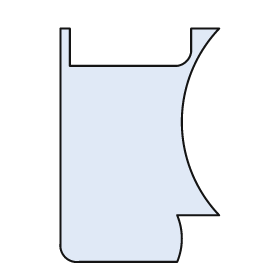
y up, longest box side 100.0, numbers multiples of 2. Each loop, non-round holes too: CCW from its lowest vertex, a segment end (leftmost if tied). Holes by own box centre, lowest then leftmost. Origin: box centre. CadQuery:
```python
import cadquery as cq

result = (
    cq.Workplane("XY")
    .moveTo(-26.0, -50.0)
    .lineTo(16.0, -50.0)
    .threePointArc((18.0, -40.0), (16.0, -30.0))
    .lineTo(34.0, -30.0)
    .threePointArc((18.0, 10.0), (34.0, 50.0))
    .lineTo(22.0, 50.0)
    .lineTo(22.0, 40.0)
    .threePointArc((20.0, 36.0), (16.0, 34.0))
    .lineTo(-30.0, 34.0)
    .lineTo(-30.0, 50.0)
    .lineTo(-34.0, 50.0)
    .lineTo(-34.0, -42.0)
    .threePointArc((-32.0, -48.0), (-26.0, -50.0))
    .close()
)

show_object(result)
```